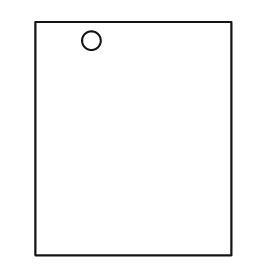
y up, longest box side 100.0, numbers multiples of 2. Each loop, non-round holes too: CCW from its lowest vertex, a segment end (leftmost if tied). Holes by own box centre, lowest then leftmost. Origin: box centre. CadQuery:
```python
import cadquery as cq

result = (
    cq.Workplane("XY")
    .moveTo(-42.0, -50.0)
    .lineTo(42.0, -50.0)
    .lineTo(42.0, 50.0)
    .lineTo(-42.0, 50.0)
    .close()
    .moveTo(-18.0, 42.0)
    .circle(4.0)
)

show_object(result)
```